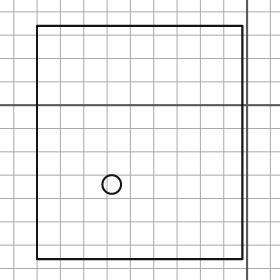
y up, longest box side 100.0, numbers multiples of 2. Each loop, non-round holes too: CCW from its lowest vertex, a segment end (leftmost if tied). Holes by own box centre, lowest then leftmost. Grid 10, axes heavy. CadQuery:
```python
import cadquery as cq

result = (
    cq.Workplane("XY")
    .moveTo(-90.0, -66.0)
    .lineTo(-2.0, -66.0)
    .lineTo(-2.0, 34.0)
    .lineTo(-90.0, 34.0)
    .close()
    .moveTo(-58.0, -34.0)
    .circle(4.0)
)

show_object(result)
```